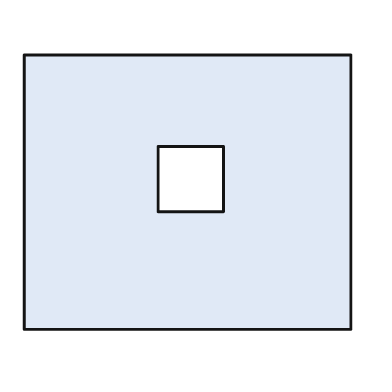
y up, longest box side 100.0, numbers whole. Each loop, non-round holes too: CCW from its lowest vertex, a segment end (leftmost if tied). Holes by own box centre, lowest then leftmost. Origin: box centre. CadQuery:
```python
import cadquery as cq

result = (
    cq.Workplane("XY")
    .moveTo(-50.0, -42.0)
    .lineTo(50.0, -42.0)
    .lineTo(50.0, 42.0)
    .lineTo(-50.0, 42.0)
    .close()
    .moveTo(-9.0, -6.0)
    .lineTo(11.0, -6.0)
    .lineTo(11.0, 14.0)
    .lineTo(-9.0, 14.0)
    .close()
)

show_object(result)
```